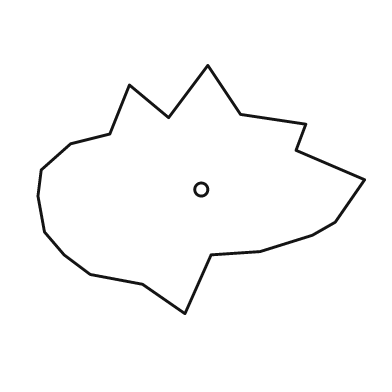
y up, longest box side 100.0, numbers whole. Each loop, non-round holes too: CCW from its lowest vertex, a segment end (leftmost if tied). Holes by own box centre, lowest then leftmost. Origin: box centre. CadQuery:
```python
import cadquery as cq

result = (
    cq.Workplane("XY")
    .moveTo(-5.0, -38.0)
    .lineTo(3.0, -20.0)
    .lineTo(18.0, -19.0)
    .lineTo(34.0, -14.0)
    .lineTo(41.0, -10.0)
    .lineTo(50.0, 3.0)
    .lineTo(29.0, 12.0)
    .lineTo(32.0, 20.0)
    .lineTo(12.0, 23.0)
    .lineTo(2.0, 38.0)
    .lineTo(-10.0, 22.0)
    .lineTo(-22.0, 32.0)
    .lineTo(-28.0, 17.0)
    .lineTo(-40.0, 14.0)
    .lineTo(-49.0, 6.0)
    .lineTo(-50.0, -2.0)
    .lineTo(-48.0, -13.0)
    .lineTo(-42.0, -20.0)
    .lineTo(-34.0, -26.0)
    .lineTo(-18.0, -29.0)
    .close()
    .moveTo(0.0, 0.0)
    .circle(2.0)
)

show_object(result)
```